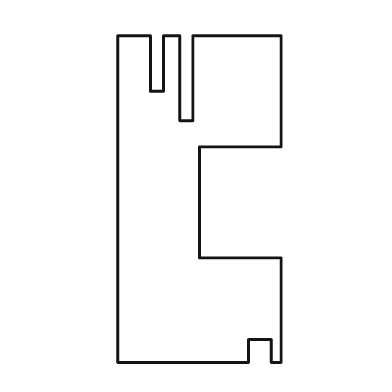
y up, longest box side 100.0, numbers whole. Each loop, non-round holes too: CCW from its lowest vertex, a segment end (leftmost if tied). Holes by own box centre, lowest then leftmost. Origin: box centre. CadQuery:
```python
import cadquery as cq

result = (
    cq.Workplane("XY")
    .moveTo(-25.0, -50.0)
    .lineTo(15.0, -50.0)
    .lineTo(15.0, -43.0)
    .lineTo(22.0, -43.0)
    .lineTo(22.0, -50.0)
    .lineTo(25.0, -50.0)
    .lineTo(25.0, -18.0)
    .lineTo(0.0, -18.0)
    .lineTo(0.0, 16.0)
    .lineTo(25.0, 16.0)
    .lineTo(25.0, 50.0)
    .lineTo(-2.0, 50.0)
    .lineTo(-2.0, 24.0)
    .lineTo(-6.0, 24.0)
    .lineTo(-6.0, 50.0)
    .lineTo(-11.0, 50.0)
    .lineTo(-11.0, 33.0)
    .lineTo(-15.0, 33.0)
    .lineTo(-15.0, 50.0)
    .lineTo(-25.0, 50.0)
    .close()
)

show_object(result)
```